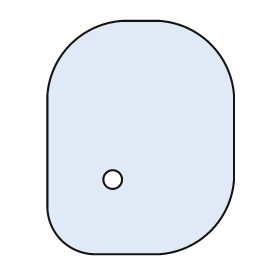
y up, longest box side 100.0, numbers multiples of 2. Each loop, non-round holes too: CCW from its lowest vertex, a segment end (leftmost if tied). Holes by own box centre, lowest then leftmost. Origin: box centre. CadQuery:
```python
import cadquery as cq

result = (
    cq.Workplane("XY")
    .moveTo(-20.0, -50.0)
    .lineTo(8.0, -50.0)
    .threePointArc((30.0, -40.0), (40.0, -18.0))
    .lineTo(40.0, 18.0)
    .threePointArc((30.0, 40.0), (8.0, 50.0))
    .lineTo(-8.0, 50.0)
    .threePointArc((-30.0, 40.0), (-40.0, 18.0))
    .lineTo(-40.0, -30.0)
    .threePointArc((-34.0, -44.0), (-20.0, -50.0))
    .close()
    .moveTo(-12.0, -18.0)
    .circle(4.0)
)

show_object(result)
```